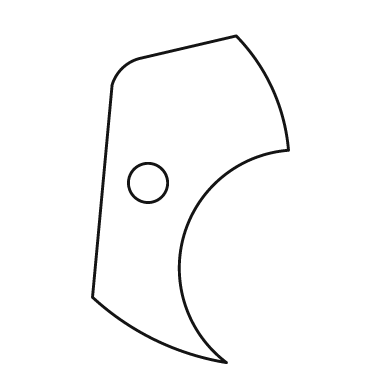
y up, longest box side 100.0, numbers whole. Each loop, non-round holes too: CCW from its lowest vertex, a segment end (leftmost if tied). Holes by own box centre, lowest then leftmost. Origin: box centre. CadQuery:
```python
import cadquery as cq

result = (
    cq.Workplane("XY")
    .moveTo(11.0, -50.0)
    .threePointArc((-2.0, -11.0), (30.0, 15.0))
    .threePointArc((25.0, 34.0), (14.0, 50.0))
    .lineTo(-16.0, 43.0)
    .threePointArc((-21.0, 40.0), (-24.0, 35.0))
    .lineTo(-30.0, -30.0)
    .threePointArc((-11.0, -43.0), (11.0, -50.0))
    .close()
    .moveTo(-13.0, 5.0)
    .circle(6.0)
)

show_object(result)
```